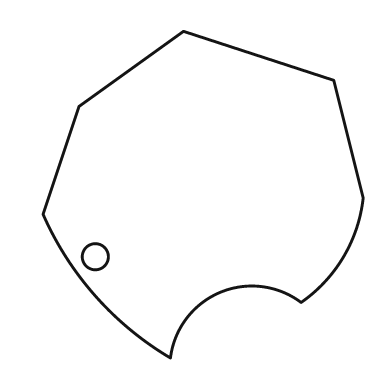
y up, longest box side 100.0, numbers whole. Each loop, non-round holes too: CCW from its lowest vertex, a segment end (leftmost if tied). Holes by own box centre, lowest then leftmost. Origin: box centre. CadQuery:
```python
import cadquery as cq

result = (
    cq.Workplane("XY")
    .moveTo(-10.0, -50.0)
    .threePointArc((5.0, -30.0), (30.0, -33.0))
    .threePointArc((43.0, -19.0), (49.0, -1.0))
    .lineTo(40.0, 35.0)
    .lineTo(-6.0, 50.0)
    .lineTo(-38.0, 27.0)
    .lineTo(-49.0, -6.0)
    .threePointArc((-33.0, -31.0), (-10.0, -50.0))
    .close()
    .moveTo(-33.0, -19.0)
    .circle(4.0)
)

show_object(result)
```